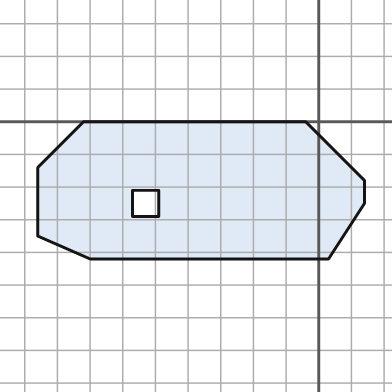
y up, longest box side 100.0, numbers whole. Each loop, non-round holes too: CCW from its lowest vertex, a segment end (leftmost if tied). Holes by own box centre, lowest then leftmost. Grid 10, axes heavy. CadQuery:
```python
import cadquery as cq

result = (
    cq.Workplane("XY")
    .moveTo(-70.0, -42.0)
    .lineTo(3.0, -42.0)
    .lineTo(14.0, -25.0)
    .lineTo(14.0, -18.0)
    .lineTo(-4.0, 0.0)
    .lineTo(-72.0, 0.0)
    .lineTo(-86.0, -14.0)
    .lineTo(-86.0, -35.0)
    .close()
    .moveTo(-57.0, -29.0)
    .lineTo(-49.0, -29.0)
    .lineTo(-49.0, -21.0)
    .lineTo(-57.0, -21.0)
    .close()
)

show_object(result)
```